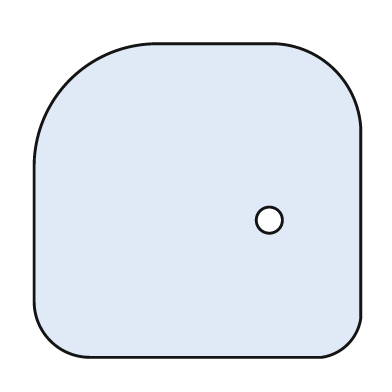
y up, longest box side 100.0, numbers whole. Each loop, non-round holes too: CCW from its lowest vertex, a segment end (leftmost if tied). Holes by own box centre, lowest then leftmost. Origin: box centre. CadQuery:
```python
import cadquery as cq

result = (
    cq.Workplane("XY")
    .moveTo(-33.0, -48.0)
    .lineTo(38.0, -48.0)
    .threePointArc((46.0, -44.0), (50.0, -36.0))
    .lineTo(50.0, 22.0)
    .threePointArc((42.0, 40.0), (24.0, 48.0))
    .lineTo(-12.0, 48.0)
    .threePointArc((-39.0, 37.0), (-50.0, 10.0))
    .lineTo(-50.0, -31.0)
    .threePointArc((-45.0, -43.0), (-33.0, -48.0))
    .close()
    .moveTo(22.0, -6.0)
    .circle(4.0)
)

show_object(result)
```